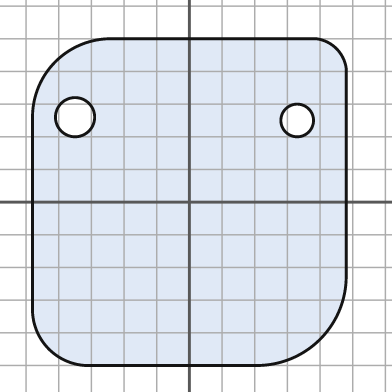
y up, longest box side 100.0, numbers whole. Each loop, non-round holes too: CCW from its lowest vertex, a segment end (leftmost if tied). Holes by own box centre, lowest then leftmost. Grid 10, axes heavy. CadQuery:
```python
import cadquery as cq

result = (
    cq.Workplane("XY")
    .moveTo(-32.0, -50.0)
    .lineTo(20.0, -50.0)
    .threePointArc((40.0, -42.0), (48.0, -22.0))
    .lineTo(48.0, 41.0)
    .threePointArc((45.0, 47.0), (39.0, 50.0))
    .lineTo(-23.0, 50.0)
    .threePointArc((-41.0, 43.0), (-48.0, 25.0))
    .lineTo(-48.0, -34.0)
    .threePointArc((-43.0, -45.0), (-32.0, -50.0))
    .close()
    .moveTo(33.0, 25.0)
    .circle(5.0)
    .moveTo(-35.0, 26.0)
    .circle(6.0)
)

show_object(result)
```